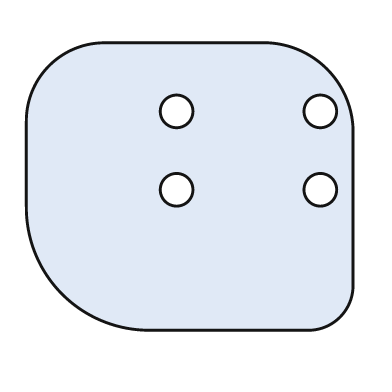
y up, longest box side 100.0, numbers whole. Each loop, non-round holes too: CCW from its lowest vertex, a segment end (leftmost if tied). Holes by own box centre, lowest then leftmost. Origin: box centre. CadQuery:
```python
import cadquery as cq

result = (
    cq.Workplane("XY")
    .moveTo(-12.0, -44.0)
    .lineTo(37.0, -44.0)
    .threePointArc((46.0, -40.0), (50.0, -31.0))
    .lineTo(50.0, 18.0)
    .threePointArc((42.0, 36.0), (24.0, 44.0))
    .lineTo(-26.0, 44.0)
    .threePointArc((-43.0, 37.0), (-50.0, 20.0))
    .lineTo(-50.0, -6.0)
    .threePointArc((-39.0, -33.0), (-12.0, -44.0))
    .close()
    .moveTo(-4.0, -1.0)
    .circle(5.0)
    .moveTo(40.0, -1.0)
    .circle(5.0)
    .moveTo(-4.0, 23.0)
    .circle(5.0)
    .moveTo(40.0, 23.0)
    .circle(5.0)
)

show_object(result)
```